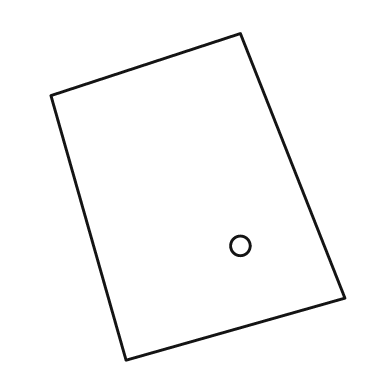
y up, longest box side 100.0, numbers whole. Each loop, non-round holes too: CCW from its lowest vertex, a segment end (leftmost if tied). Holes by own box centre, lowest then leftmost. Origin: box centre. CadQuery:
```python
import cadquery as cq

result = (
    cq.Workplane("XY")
    .moveTo(-22.0, -50.0)
    .lineTo(45.0, -31.0)
    .lineTo(13.0, 50.0)
    .lineTo(-45.0, 31.0)
    .close()
    .moveTo(13.0, -15.0)
    .circle(3.0)
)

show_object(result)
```